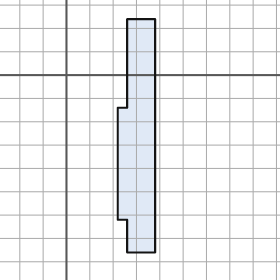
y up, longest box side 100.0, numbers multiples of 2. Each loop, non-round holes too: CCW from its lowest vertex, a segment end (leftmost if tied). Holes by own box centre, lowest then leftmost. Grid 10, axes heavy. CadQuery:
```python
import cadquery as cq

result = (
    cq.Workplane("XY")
    .moveTo(26.0, -76.0)
    .lineTo(38.0, -76.0)
    .lineTo(38.0, 24.0)
    .lineTo(26.0, 24.0)
    .lineTo(26.0, -14.0)
    .lineTo(22.0, -14.0)
    .lineTo(22.0, -62.0)
    .lineTo(26.0, -62.0)
    .close()
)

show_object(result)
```